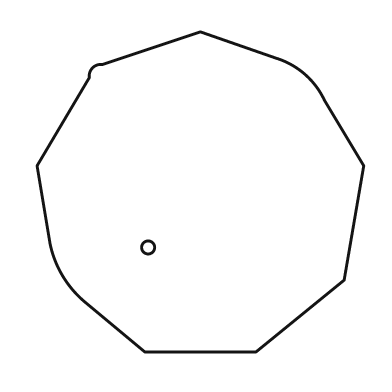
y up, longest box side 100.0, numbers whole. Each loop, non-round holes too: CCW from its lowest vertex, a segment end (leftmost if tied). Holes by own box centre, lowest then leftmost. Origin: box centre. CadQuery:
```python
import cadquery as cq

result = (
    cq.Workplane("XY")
    .moveTo(-17.0, -49.0)
    .lineTo(17.0, -49.0)
    .lineTo(44.0, -27.0)
    .lineTo(50.0, 8.0)
    .lineTo(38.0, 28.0)
    .threePointArc((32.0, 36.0), (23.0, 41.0))
    .lineTo(0.0, 49.0)
    .lineTo(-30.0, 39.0)
    .threePointArc((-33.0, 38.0), (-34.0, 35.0))
    .lineTo(-50.0, 8.0)
    .lineTo(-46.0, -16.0)
    .threePointArc((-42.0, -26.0), (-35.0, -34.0))
    .close()
    .moveTo(-16.0, -17.0)
    .circle(2.0)
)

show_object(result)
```